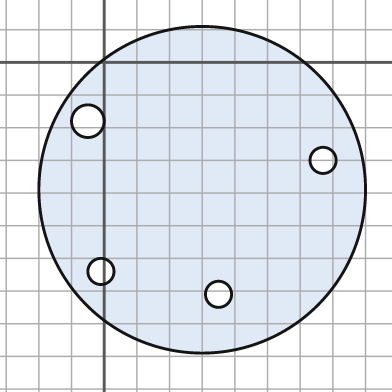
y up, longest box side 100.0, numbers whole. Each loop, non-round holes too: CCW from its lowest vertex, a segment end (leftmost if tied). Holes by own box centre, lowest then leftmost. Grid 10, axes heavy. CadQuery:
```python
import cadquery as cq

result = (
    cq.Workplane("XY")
    .moveTo(30.0, -39.0)
    .circle(50.0)
    .moveTo(35.0, -71.0)
    .circle(4.0)
    .moveTo(-1.0, -64.0)
    .circle(4.0)
    .moveTo(67.0, -30.0)
    .circle(4.0)
    .moveTo(-5.0, -18.0)
    .circle(5.0)
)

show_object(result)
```